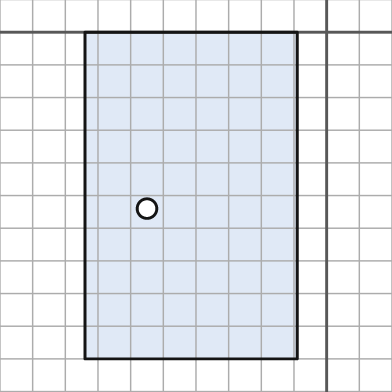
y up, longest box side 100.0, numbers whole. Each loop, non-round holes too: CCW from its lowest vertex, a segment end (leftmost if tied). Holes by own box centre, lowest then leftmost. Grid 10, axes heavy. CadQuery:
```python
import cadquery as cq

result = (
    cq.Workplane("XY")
    .moveTo(-74.0, -100.0)
    .lineTo(-9.0, -100.0)
    .lineTo(-9.0, 0.0)
    .lineTo(-74.0, 0.0)
    .close()
    .moveTo(-55.0, -54.0)
    .circle(3.0)
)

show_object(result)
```